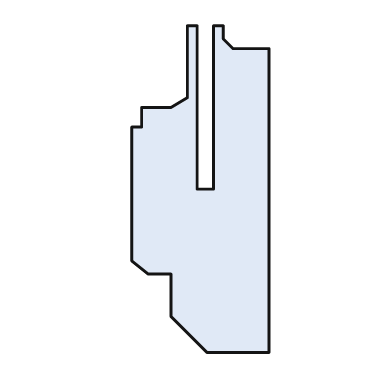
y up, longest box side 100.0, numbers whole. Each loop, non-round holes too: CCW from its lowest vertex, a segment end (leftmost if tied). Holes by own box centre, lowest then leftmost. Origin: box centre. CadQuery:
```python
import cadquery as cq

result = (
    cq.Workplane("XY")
    .moveTo(2.0, -50.0)
    .lineTo(21.0, -50.0)
    .lineTo(21.0, 43.0)
    .lineTo(10.0, 43.0)
    .lineTo(7.0, 46.0)
    .lineTo(7.0, 50.0)
    .lineTo(4.0, 50.0)
    .lineTo(4.0, 0.0)
    .lineTo(-1.0, 0.0)
    .lineTo(-1.0, 50.0)
    .lineTo(-4.0, 50.0)
    .lineTo(-4.0, 28.0)
    .lineTo(-9.0, 25.0)
    .lineTo(-18.0, 25.0)
    .lineTo(-18.0, 19.0)
    .lineTo(-21.0, 19.0)
    .lineTo(-21.0, -22.0)
    .lineTo(-16.0, -26.0)
    .lineTo(-9.0, -26.0)
    .lineTo(-9.0, -39.0)
    .close()
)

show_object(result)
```